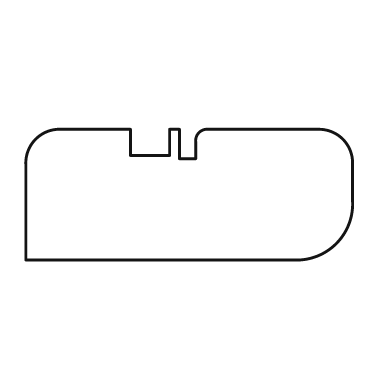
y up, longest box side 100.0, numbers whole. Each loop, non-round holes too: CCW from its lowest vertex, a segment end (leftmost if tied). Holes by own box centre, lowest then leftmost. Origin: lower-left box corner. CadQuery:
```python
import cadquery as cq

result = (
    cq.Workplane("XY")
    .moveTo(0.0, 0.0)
    .lineTo(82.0, 0.0)
    .threePointArc((95.0, 5.0), (100.0, 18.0))
    .lineTo(100.0, 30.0)
    .threePointArc((97.0, 37.0), (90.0, 40.0))
    .lineTo(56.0, 40.0)
    .threePointArc((53.0, 39.0), (52.0, 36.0))
    .lineTo(52.0, 31.0)
    .lineTo(47.0, 31.0)
    .lineTo(47.0, 40.0)
    .lineTo(44.0, 40.0)
    .lineTo(44.0, 32.0)
    .lineTo(32.0, 32.0)
    .lineTo(32.0, 40.0)
    .lineTo(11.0, 40.0)
    .threePointArc((3.0, 37.0), (0.0, 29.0))
    .close()
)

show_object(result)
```